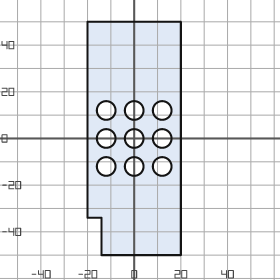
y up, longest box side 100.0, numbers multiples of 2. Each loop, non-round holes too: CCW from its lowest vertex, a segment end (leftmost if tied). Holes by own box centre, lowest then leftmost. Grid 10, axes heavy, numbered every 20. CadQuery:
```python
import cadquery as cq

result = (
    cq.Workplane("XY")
    .moveTo(-14.0, -50.0)
    .lineTo(20.0, -50.0)
    .lineTo(20.0, 50.0)
    .lineTo(-20.0, 50.0)
    .lineTo(-20.0, -34.0)
    .lineTo(-14.0, -34.0)
    .close()
    .moveTo(-12.0, -12.0)
    .circle(4.0)
    .moveTo(0.0, -12.0)
    .circle(4.0)
    .moveTo(12.0, -12.0)
    .circle(4.0)
    .moveTo(-12.0, 0.0)
    .circle(4.0)
    .moveTo(0.0, 0.0)
    .circle(4.0)
    .moveTo(12.0, 0.0)
    .circle(4.0)
    .moveTo(-12.0, 12.0)
    .circle(4.0)
    .moveTo(0.0, 12.0)
    .circle(4.0)
    .moveTo(12.0, 12.0)
    .circle(4.0)
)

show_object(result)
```